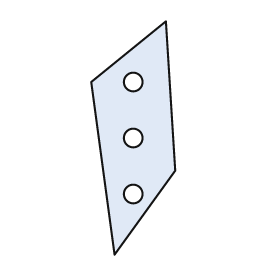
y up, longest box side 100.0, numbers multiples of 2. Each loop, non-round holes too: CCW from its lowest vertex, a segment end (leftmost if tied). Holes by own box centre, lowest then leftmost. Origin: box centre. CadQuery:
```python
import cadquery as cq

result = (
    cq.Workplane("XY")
    .moveTo(-8.0, -50.0)
    .lineTo(18.0, -14.0)
    .lineTo(14.0, 50.0)
    .lineTo(-18.0, 24.0)
    .close()
    .moveTo(0.0, -24.0)
    .circle(4.0)
    .moveTo(0.0, 0.0)
    .circle(4.0)
    .moveTo(0.0, 24.0)
    .circle(4.0)
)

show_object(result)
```